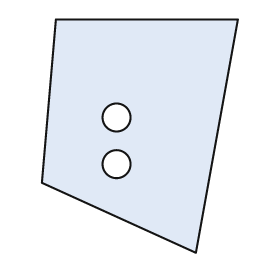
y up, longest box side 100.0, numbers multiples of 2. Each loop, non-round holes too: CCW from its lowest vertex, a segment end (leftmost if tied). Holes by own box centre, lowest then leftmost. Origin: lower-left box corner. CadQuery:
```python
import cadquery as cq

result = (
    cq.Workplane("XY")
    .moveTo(66.0, 0.0)
    .lineTo(84.0, 100.0)
    .lineTo(6.0, 100.0)
    .lineTo(0.0, 30.0)
    .close()
    .moveTo(32.0, 38.0)
    .circle(6.0)
    .moveTo(32.0, 58.0)
    .circle(6.0)
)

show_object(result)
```